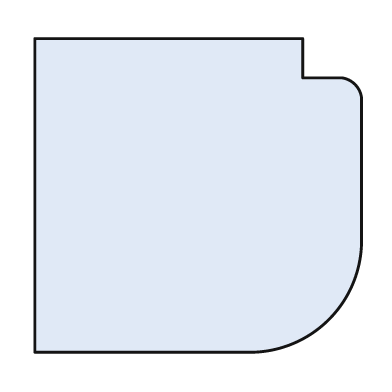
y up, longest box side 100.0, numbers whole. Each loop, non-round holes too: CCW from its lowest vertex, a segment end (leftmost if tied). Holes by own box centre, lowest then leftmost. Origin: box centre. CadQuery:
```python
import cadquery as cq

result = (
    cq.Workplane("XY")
    .moveTo(-50.0, -48.0)
    .lineTo(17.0, -48.0)
    .threePointArc((40.0, -38.0), (50.0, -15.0))
    .lineTo(50.0, 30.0)
    .threePointArc((48.0, 34.0), (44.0, 36.0))
    .lineTo(32.0, 36.0)
    .lineTo(32.0, 48.0)
    .lineTo(-50.0, 48.0)
    .close()
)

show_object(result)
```